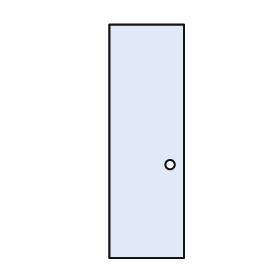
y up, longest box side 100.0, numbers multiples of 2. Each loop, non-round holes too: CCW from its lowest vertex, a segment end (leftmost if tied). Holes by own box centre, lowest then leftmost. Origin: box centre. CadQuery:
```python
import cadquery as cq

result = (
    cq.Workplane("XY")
    .moveTo(-16.0, -50.0)
    .lineTo(16.0, -50.0)
    .lineTo(16.0, 50.0)
    .lineTo(-16.0, 50.0)
    .close()
    .moveTo(10.0, -10.0)
    .circle(2.0)
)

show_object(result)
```